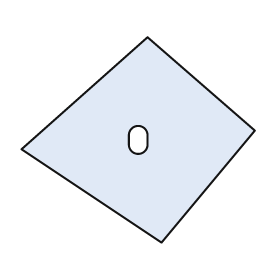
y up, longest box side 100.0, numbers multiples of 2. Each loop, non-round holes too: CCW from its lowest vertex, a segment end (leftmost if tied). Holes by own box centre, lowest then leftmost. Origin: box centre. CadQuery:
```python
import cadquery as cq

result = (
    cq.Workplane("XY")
    .moveTo(10.0, -44.0)
    .lineTo(50.0, 4.0)
    .lineTo(4.0, 44.0)
    .lineTo(-50.0, -4.0)
    .close()
    .moveTo(-4.0, -2.0)
    .threePointArc((0.0, -6.0), (4.0, -2.0))
    .lineTo(4.0, 2.0)
    .threePointArc((0.0, 6.0), (-4.0, 2.0))
    .close()
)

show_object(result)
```